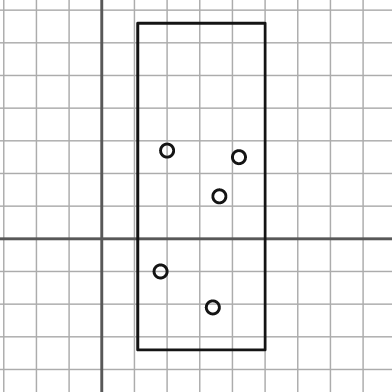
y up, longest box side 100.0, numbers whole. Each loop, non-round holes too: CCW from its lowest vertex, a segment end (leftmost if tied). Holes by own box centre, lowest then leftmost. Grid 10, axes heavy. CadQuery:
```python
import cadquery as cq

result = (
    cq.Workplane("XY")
    .moveTo(11.0, -34.0)
    .lineTo(50.0, -34.0)
    .lineTo(50.0, 66.0)
    .lineTo(11.0, 66.0)
    .close()
    .moveTo(34.0, -21.0)
    .circle(2.0)
    .moveTo(18.0, -10.0)
    .circle(2.0)
    .moveTo(36.0, 13.0)
    .circle(2.0)
    .moveTo(42.0, 25.0)
    .circle(2.0)
    .moveTo(20.0, 27.0)
    .circle(2.0)
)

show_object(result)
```